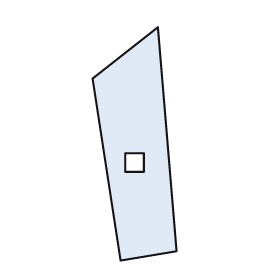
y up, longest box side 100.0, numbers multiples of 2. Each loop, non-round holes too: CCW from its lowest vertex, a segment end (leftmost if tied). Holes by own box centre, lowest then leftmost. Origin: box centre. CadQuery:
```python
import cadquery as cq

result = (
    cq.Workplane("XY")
    .moveTo(-6.0, -50.0)
    .lineTo(18.0, -46.0)
    .lineTo(10.0, 50.0)
    .lineTo(-18.0, 28.0)
    .close()
    .moveTo(-4.0, -12.0)
    .lineTo(4.0, -12.0)
    .lineTo(4.0, -4.0)
    .lineTo(-4.0, -4.0)
    .close()
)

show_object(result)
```